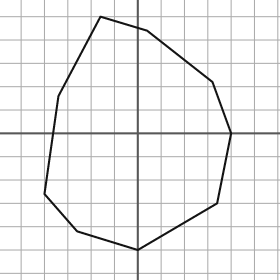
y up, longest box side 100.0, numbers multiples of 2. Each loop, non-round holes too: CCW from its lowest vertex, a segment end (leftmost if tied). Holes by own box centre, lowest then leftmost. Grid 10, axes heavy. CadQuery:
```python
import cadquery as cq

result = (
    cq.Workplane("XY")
    .moveTo(0.0, -50.0)
    .lineTo(34.0, -30.0)
    .lineTo(40.0, 0.0)
    .lineTo(32.0, 22.0)
    .lineTo(4.0, 44.0)
    .lineTo(-16.0, 50.0)
    .lineTo(-34.0, 16.0)
    .lineTo(-40.0, -26.0)
    .lineTo(-26.0, -42.0)
    .close()
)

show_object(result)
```